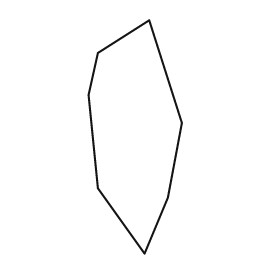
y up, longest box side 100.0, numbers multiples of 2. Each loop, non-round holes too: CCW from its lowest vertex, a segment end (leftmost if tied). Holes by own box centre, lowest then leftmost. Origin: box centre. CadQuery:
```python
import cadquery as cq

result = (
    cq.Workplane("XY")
    .moveTo(4.0, -50.0)
    .lineTo(14.0, -26.0)
    .lineTo(20.0, 6.0)
    .lineTo(6.0, 50.0)
    .lineTo(-16.0, 36.0)
    .lineTo(-20.0, 18.0)
    .lineTo(-16.0, -22.0)
    .close()
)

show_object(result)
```